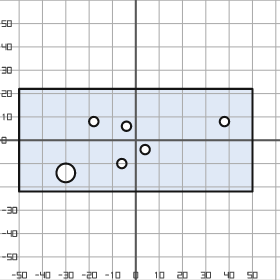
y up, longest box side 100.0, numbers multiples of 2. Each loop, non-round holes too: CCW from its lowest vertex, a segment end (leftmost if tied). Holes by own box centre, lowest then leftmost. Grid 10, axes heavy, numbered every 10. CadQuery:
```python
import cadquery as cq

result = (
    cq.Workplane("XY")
    .moveTo(-50.0, -22.0)
    .lineTo(50.0, -22.0)
    .lineTo(50.0, 22.0)
    .lineTo(-50.0, 22.0)
    .close()
    .moveTo(-30.0, -14.0)
    .circle(4.0)
    .moveTo(-6.0, -10.0)
    .circle(2.0)
    .moveTo(4.0, -4.0)
    .circle(2.0)
    .moveTo(-4.0, 6.0)
    .circle(2.0)
    .moveTo(-18.0, 8.0)
    .circle(2.0)
    .moveTo(38.0, 8.0)
    .circle(2.0)
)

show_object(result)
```